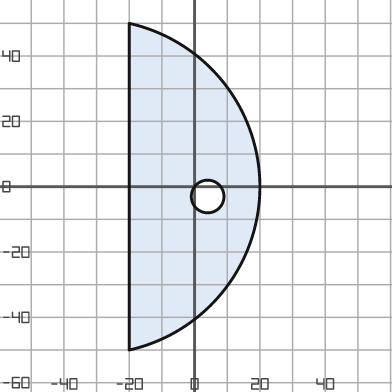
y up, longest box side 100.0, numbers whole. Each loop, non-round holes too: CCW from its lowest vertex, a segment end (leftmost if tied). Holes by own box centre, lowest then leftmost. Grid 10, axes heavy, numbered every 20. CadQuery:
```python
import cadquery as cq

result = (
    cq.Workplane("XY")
    .moveTo(-20.0, -50.0)
    .threePointArc((20.0, 0.0), (-20.0, 50.0))
    .close()
    .moveTo(4.0, -3.0)
    .circle(5.0)
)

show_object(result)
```